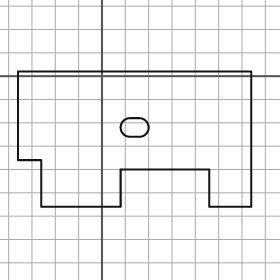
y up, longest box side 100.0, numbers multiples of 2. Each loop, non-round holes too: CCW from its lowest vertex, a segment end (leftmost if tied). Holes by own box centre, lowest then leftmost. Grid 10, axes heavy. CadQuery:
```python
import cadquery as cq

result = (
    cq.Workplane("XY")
    .moveTo(-26.0, -56.0)
    .lineTo(8.0, -56.0)
    .lineTo(8.0, -40.0)
    .lineTo(46.0, -40.0)
    .lineTo(46.0, -56.0)
    .lineTo(64.0, -56.0)
    .lineTo(64.0, 2.0)
    .lineTo(-36.0, 2.0)
    .lineTo(-36.0, -36.0)
    .lineTo(-26.0, -36.0)
    .close()
    .moveTo(12.0, -26.0)
    .lineTo(16.0, -26.0)
    .threePointArc((20.0, -22.0), (16.0, -18.0))
    .lineTo(12.0, -18.0)
    .threePointArc((8.0, -22.0), (12.0, -26.0))
    .close()
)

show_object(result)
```